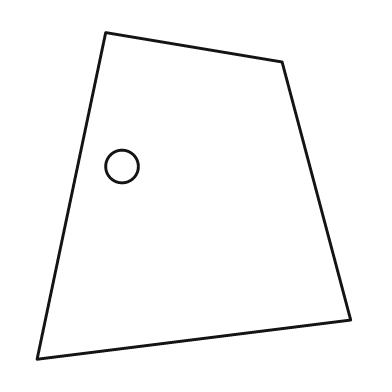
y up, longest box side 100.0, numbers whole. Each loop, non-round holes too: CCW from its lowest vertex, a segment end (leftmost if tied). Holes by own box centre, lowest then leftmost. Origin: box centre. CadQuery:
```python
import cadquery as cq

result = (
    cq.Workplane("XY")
    .moveTo(-48.0, -50.0)
    .lineTo(48.0, -38.0)
    .lineTo(27.0, 41.0)
    .lineTo(-27.0, 50.0)
    .close()
    .moveTo(-22.0, 9.0)
    .circle(5.0)
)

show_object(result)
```